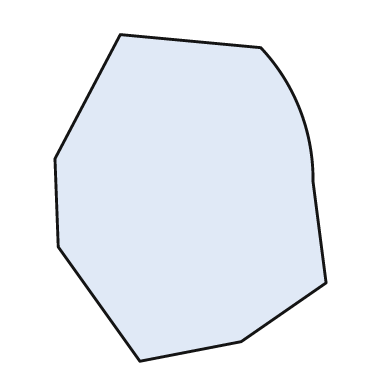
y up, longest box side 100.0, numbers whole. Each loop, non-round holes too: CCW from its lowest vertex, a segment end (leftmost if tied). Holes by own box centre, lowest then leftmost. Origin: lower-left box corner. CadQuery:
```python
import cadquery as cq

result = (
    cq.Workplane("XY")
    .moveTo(26.0, 0.0)
    .lineTo(57.0, 6.0)
    .lineTo(83.0, 24.0)
    .lineTo(79.0, 55.0)
    .threePointArc((75.0, 77.0), (63.0, 96.0))
    .lineTo(20.0, 100.0)
    .lineTo(0.0, 62.0)
    .lineTo(1.0, 35.0)
    .close()
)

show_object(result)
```